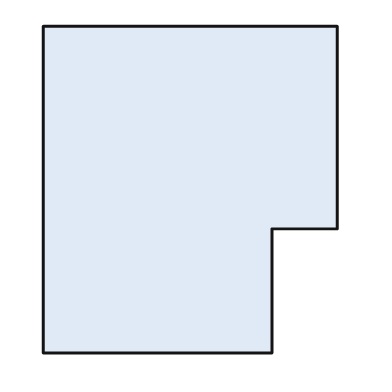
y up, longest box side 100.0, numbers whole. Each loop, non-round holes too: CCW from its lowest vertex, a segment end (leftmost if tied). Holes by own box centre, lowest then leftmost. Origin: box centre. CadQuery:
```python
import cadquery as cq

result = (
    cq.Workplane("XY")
    .moveTo(-45.0, -50.0)
    .lineTo(25.0, -50.0)
    .lineTo(25.0, -12.0)
    .lineTo(45.0, -12.0)
    .lineTo(45.0, 50.0)
    .lineTo(-45.0, 50.0)
    .close()
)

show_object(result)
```